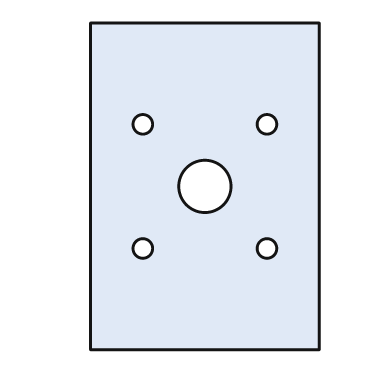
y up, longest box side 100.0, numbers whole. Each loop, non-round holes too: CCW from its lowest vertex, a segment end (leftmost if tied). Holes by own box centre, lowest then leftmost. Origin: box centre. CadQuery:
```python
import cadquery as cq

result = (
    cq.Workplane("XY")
    .moveTo(-35.0, -50.0)
    .lineTo(35.0, -50.0)
    .lineTo(35.0, 50.0)
    .lineTo(-35.0, 50.0)
    .close()
    .moveTo(-19.0, -19.0)
    .circle(3.0)
    .moveTo(19.0, -19.0)
    .circle(3.0)
    .moveTo(0.0, 0.0)
    .circle(8.0)
    .moveTo(-19.0, 19.0)
    .circle(3.0)
    .moveTo(19.0, 19.0)
    .circle(3.0)
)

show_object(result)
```